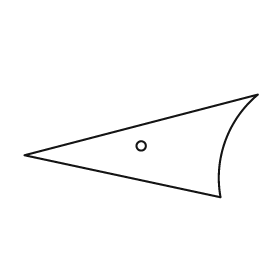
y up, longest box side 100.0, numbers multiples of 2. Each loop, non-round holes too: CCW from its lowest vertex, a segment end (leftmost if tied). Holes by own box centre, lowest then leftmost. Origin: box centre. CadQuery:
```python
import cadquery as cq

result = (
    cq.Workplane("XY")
    .moveTo(34.0, -22.0)
    .threePointArc((36.0, 2.0), (50.0, 22.0))
    .lineTo(-50.0, -4.0)
    .close()
    .moveTo(0.0, 0.0)
    .circle(2.0)
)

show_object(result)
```